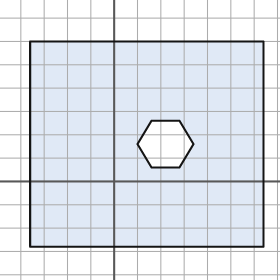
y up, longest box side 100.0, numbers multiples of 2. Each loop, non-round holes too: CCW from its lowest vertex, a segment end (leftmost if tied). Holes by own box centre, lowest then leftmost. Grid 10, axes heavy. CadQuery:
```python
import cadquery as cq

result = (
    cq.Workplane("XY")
    .moveTo(-36.0, -28.0)
    .lineTo(64.0, -28.0)
    .lineTo(64.0, 60.0)
    .lineTo(-36.0, 60.0)
    .close()
    .moveTo(16.0, 6.0)
    .lineTo(28.0, 6.0)
    .lineTo(34.0, 16.0)
    .lineTo(28.0, 26.0)
    .lineTo(16.0, 26.0)
    .lineTo(10.0, 16.0)
    .close()
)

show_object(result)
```